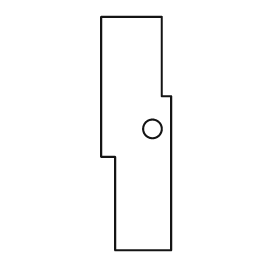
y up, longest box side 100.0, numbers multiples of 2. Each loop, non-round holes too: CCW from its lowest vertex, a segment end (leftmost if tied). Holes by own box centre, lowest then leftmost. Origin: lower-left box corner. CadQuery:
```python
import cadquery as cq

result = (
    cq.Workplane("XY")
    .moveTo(6.0, 0.0)
    .lineTo(30.0, 0.0)
    .lineTo(30.0, 66.0)
    .lineTo(26.0, 66.0)
    .lineTo(26.0, 100.0)
    .lineTo(0.0, 100.0)
    .lineTo(0.0, 40.0)
    .lineTo(6.0, 40.0)
    .close()
    .moveTo(22.0, 52.0)
    .circle(4.0)
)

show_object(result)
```